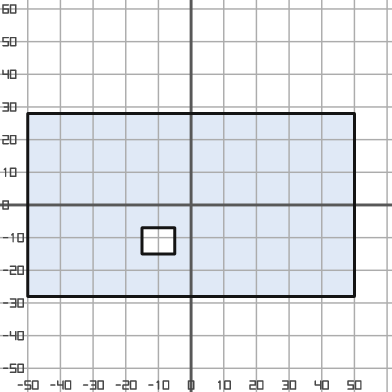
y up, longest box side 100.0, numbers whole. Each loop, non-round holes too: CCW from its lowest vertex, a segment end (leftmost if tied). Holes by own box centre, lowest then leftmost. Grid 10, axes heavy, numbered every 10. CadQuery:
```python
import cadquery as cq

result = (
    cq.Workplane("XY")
    .moveTo(-50.0, -28.0)
    .lineTo(50.0, -28.0)
    .lineTo(50.0, 28.0)
    .lineTo(-50.0, 28.0)
    .close()
    .moveTo(-15.0, -15.0)
    .lineTo(-5.0, -15.0)
    .lineTo(-5.0, -7.0)
    .lineTo(-15.0, -7.0)
    .close()
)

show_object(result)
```